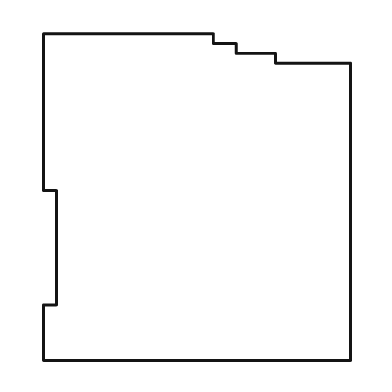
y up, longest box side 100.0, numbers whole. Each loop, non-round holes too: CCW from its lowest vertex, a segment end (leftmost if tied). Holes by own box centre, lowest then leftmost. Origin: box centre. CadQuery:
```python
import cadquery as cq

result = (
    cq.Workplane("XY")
    .moveTo(-47.0, -50.0)
    .lineTo(47.0, -50.0)
    .lineTo(47.0, 41.0)
    .lineTo(24.0, 41.0)
    .lineTo(24.0, 44.0)
    .lineTo(12.0, 44.0)
    .lineTo(12.0, 47.0)
    .lineTo(5.0, 47.0)
    .lineTo(5.0, 50.0)
    .lineTo(-47.0, 50.0)
    .lineTo(-47.0, 2.0)
    .lineTo(-43.0, 2.0)
    .lineTo(-43.0, -33.0)
    .lineTo(-47.0, -33.0)
    .close()
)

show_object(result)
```